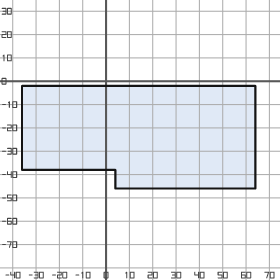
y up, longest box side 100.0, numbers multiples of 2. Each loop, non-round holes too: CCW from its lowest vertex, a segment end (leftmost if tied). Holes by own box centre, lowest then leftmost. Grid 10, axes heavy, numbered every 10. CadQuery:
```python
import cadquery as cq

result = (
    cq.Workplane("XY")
    .moveTo(4.0, -46.0)
    .lineTo(64.0, -46.0)
    .lineTo(64.0, -2.0)
    .lineTo(-36.0, -2.0)
    .lineTo(-36.0, -38.0)
    .lineTo(4.0, -38.0)
    .close()
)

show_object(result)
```